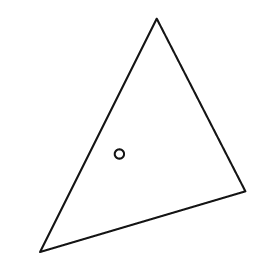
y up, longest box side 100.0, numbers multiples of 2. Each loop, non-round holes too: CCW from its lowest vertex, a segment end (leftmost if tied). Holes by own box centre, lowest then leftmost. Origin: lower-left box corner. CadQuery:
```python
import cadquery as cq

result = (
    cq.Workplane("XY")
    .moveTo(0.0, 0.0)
    .lineTo(88.0, 26.0)
    .lineTo(50.0, 100.0)
    .close()
    .moveTo(34.0, 42.0)
    .circle(2.0)
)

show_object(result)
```